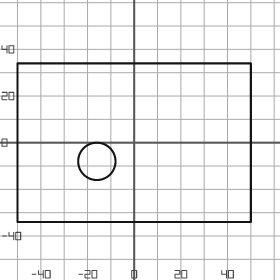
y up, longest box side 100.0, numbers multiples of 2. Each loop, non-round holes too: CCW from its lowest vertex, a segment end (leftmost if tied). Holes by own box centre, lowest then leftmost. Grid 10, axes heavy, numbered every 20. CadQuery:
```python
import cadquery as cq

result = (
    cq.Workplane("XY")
    .moveTo(-50.0, -34.0)
    .lineTo(50.0, -34.0)
    .lineTo(50.0, 34.0)
    .lineTo(-50.0, 34.0)
    .close()
    .moveTo(-16.0, -8.0)
    .circle(8.0)
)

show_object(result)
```